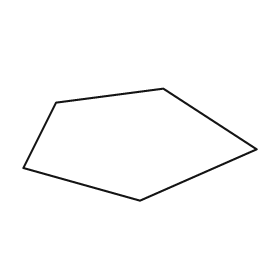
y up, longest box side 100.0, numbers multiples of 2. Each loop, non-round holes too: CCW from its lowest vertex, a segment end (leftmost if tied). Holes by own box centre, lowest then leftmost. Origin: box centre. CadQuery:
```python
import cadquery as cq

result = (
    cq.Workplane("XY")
    .moveTo(0.0, -24.0)
    .lineTo(50.0, -2.0)
    .lineTo(10.0, 24.0)
    .lineTo(-36.0, 18.0)
    .lineTo(-50.0, -10.0)
    .close()
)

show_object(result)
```